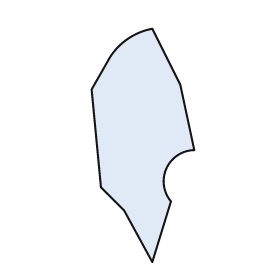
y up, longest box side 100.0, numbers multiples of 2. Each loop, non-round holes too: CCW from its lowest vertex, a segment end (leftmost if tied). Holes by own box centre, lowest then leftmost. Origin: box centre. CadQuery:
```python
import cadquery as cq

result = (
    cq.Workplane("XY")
    .moveTo(4.0, -50.0)
    .lineTo(12.0, -24.0)
    .threePointArc((10.0, -10.0), (22.0, -2.0))
    .lineTo(16.0, 26.0)
    .lineTo(4.0, 50.0)
    .threePointArc((-6.0, 46.0), (-14.0, 38.0))
    .lineTo(-22.0, 24.0)
    .lineTo(-18.0, -18.0)
    .lineTo(-8.0, -28.0)
    .close()
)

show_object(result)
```